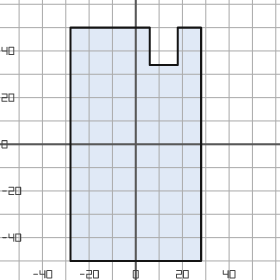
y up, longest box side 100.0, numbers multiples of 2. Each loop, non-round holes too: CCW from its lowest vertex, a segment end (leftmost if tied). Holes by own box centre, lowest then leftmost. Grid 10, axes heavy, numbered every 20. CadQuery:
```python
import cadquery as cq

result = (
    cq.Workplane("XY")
    .moveTo(-28.0, -50.0)
    .lineTo(28.0, -50.0)
    .lineTo(28.0, 50.0)
    .lineTo(18.0, 50.0)
    .lineTo(18.0, 34.0)
    .lineTo(6.0, 34.0)
    .lineTo(6.0, 50.0)
    .lineTo(-28.0, 50.0)
    .close()
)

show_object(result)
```